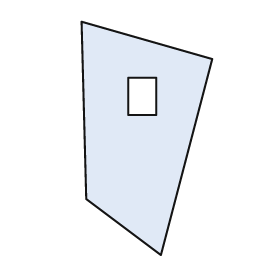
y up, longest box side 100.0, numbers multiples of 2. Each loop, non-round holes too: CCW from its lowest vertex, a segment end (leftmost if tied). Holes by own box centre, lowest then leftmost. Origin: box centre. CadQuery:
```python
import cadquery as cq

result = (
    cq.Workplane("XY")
    .moveTo(6.0, -50.0)
    .lineTo(28.0, 34.0)
    .lineTo(-28.0, 50.0)
    .lineTo(-26.0, -26.0)
    .close()
    .moveTo(-8.0, 10.0)
    .lineTo(4.0, 10.0)
    .lineTo(4.0, 26.0)
    .lineTo(-8.0, 26.0)
    .close()
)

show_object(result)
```